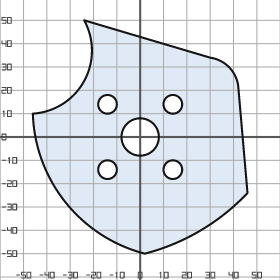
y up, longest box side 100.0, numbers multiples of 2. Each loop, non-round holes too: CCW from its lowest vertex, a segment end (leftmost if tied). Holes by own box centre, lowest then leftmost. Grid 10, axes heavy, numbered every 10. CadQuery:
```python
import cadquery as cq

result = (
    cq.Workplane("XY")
    .moveTo(2.0, -50.0)
    .threePointArc((26.0, -40.0), (46.0, -24.0))
    .lineTo(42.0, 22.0)
    .threePointArc((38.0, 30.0), (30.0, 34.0))
    .lineTo(-24.0, 50.0)
    .threePointArc((-24.0, 24.0), (-46.0, 10.0))
    .threePointArc((-32.0, -28.0), (2.0, -50.0))
    .close()
    .moveTo(-14.0, -14.0)
    .circle(4.0)
    .moveTo(14.0, -14.0)
    .circle(4.0)
    .moveTo(0.0, 0.0)
    .circle(8.0)
    .moveTo(-14.0, 14.0)
    .circle(4.0)
    .moveTo(14.0, 14.0)
    .circle(4.0)
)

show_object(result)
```